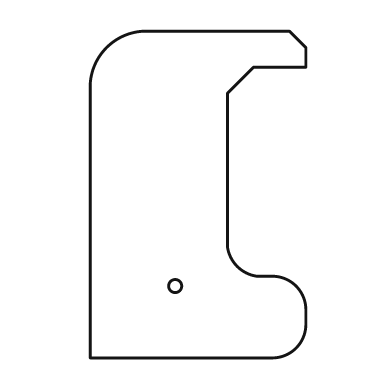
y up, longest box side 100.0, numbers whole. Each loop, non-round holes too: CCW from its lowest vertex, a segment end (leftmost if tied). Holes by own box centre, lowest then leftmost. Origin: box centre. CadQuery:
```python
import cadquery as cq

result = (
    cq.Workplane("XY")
    .moveTo(-33.0, -50.0)
    .lineTo(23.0, -50.0)
    .threePointArc((30.0, -47.0), (33.0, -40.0))
    .lineTo(33.0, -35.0)
    .threePointArc((30.0, -28.0), (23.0, -25.0))
    .lineTo(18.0, -25.0)
    .threePointArc((12.0, -22.0), (9.0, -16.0))
    .lineTo(9.0, 31.0)
    .lineTo(17.0, 39.0)
    .lineTo(33.0, 39.0)
    .lineTo(33.0, 45.0)
    .lineTo(28.0, 50.0)
    .lineTo(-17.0, 50.0)
    .threePointArc((-28.0, 45.0), (-33.0, 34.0))
    .close()
    .moveTo(-7.0, -28.0)
    .circle(2.0)
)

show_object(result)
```